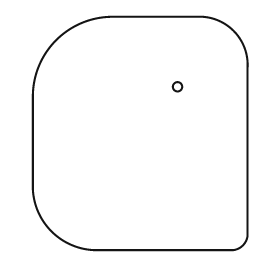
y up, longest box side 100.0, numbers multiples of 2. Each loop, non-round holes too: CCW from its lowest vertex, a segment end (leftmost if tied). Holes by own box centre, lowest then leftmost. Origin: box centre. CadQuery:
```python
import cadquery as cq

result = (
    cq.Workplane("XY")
    .moveTo(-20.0, -50.0)
    .lineTo(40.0, -50.0)
    .threePointArc((44.0, -48.0), (46.0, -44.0))
    .lineTo(46.0, 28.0)
    .threePointArc((40.0, 44.0), (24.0, 50.0))
    .lineTo(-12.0, 50.0)
    .threePointArc((-36.0, 40.0), (-46.0, 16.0))
    .lineTo(-46.0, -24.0)
    .threePointArc((-38.0, -42.0), (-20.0, -50.0))
    .close()
    .moveTo(16.0, 20.0)
    .circle(2.0)
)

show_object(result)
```